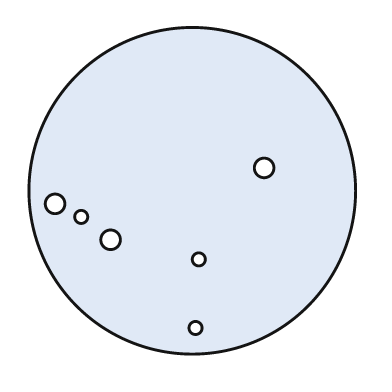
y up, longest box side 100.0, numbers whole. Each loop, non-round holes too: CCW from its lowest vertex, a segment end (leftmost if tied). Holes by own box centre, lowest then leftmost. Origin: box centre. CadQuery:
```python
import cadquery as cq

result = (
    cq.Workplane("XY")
    .moveTo(0.0, 0.0)
    .circle(50.0)
    .moveTo(1.0, -42.0)
    .circle(2.0)
    .moveTo(2.0, -21.0)
    .circle(2.0)
    .moveTo(-25.0, -15.0)
    .circle(3.0)
    .moveTo(-34.0, -8.0)
    .circle(2.0)
    .moveTo(-42.0, -4.0)
    .circle(3.0)
    .moveTo(22.0, 7.0)
    .circle(3.0)
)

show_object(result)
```